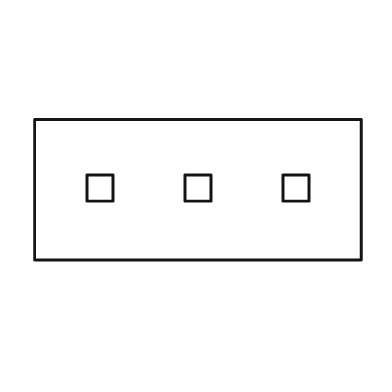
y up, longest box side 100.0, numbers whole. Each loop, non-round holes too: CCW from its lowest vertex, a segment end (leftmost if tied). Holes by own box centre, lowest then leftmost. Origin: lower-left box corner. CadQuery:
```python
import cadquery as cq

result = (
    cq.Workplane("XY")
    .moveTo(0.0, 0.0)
    .lineTo(100.0, 0.0)
    .lineTo(100.0, 43.0)
    .lineTo(0.0, 43.0)
    .close()
    .moveTo(16.0, 18.0)
    .lineTo(24.0, 18.0)
    .lineTo(24.0, 26.0)
    .lineTo(16.0, 26.0)
    .close()
    .moveTo(46.0, 18.0)
    .lineTo(54.0, 18.0)
    .lineTo(54.0, 26.0)
    .lineTo(46.0, 26.0)
    .close()
    .moveTo(76.0, 18.0)
    .lineTo(84.0, 18.0)
    .lineTo(84.0, 26.0)
    .lineTo(76.0, 26.0)
    .close()
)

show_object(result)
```